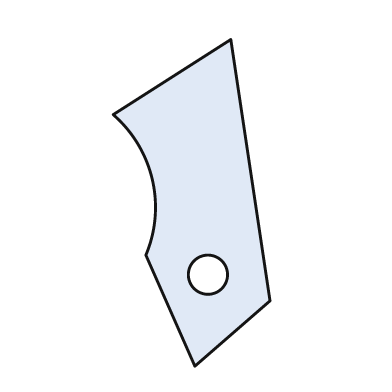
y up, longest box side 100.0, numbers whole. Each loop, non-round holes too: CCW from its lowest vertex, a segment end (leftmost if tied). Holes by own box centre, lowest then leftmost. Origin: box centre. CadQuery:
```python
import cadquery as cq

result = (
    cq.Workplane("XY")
    .moveTo(1.0, -50.0)
    .lineTo(24.0, -30.0)
    .lineTo(12.0, 50.0)
    .lineTo(-24.0, 27.0)
    .threePointArc((-12.0, 7.0), (-14.0, -16.0))
    .close()
    .moveTo(5.0, -22.0)
    .circle(6.0)
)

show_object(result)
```